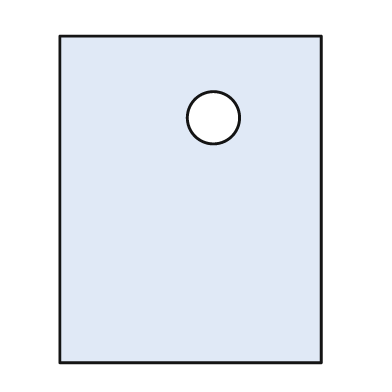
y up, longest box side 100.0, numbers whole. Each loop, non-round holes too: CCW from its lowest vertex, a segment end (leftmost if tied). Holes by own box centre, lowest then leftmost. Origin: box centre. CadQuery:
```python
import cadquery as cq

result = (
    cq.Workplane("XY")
    .moveTo(-40.0, -50.0)
    .lineTo(40.0, -50.0)
    .lineTo(40.0, 50.0)
    .lineTo(-40.0, 50.0)
    .close()
    .moveTo(7.0, 25.0)
    .circle(8.0)
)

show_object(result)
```